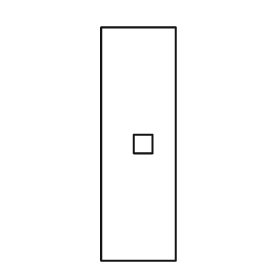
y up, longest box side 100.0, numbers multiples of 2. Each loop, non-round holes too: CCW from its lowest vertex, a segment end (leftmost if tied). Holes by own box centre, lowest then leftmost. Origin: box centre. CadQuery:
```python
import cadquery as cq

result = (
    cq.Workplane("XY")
    .moveTo(-16.0, -50.0)
    .lineTo(16.0, -50.0)
    .lineTo(16.0, 50.0)
    .lineTo(-16.0, 50.0)
    .close()
    .moveTo(-2.0, -4.0)
    .lineTo(6.0, -4.0)
    .lineTo(6.0, 4.0)
    .lineTo(-2.0, 4.0)
    .close()
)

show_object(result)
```